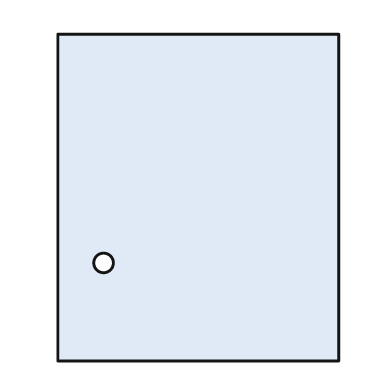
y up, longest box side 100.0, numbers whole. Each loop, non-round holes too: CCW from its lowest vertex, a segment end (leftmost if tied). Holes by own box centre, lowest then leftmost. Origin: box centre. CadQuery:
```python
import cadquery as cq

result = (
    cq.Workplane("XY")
    .moveTo(-43.0, -50.0)
    .lineTo(43.0, -50.0)
    .lineTo(43.0, 50.0)
    .lineTo(-43.0, 50.0)
    .close()
    .moveTo(-29.0, -20.0)
    .circle(3.0)
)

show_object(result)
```